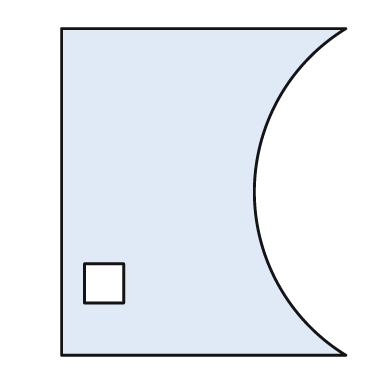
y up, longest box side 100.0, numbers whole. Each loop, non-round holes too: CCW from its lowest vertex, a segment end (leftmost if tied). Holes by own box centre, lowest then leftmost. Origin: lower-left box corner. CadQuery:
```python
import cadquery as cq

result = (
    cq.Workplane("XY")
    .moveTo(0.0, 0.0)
    .lineTo(87.0, 0.0)
    .threePointArc((59.0, 50.0), (87.0, 100.0))
    .lineTo(0.0, 100.0)
    .close()
    .moveTo(7.0, 16.0)
    .lineTo(19.0, 16.0)
    .lineTo(19.0, 28.0)
    .lineTo(7.0, 28.0)
    .close()
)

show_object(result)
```